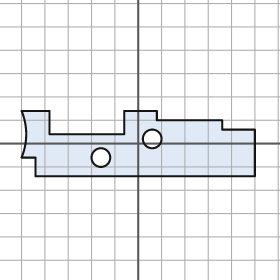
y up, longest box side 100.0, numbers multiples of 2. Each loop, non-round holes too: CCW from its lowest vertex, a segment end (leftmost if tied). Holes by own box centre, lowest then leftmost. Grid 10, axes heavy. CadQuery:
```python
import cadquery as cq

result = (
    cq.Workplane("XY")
    .moveTo(-44.0, -14.0)
    .lineTo(50.0, -14.0)
    .lineTo(50.0, 6.0)
    .lineTo(36.0, 6.0)
    .lineTo(36.0, 10.0)
    .lineTo(8.0, 10.0)
    .lineTo(8.0, 14.0)
    .lineTo(-6.0, 14.0)
    .lineTo(-6.0, 4.0)
    .lineTo(-38.0, 4.0)
    .lineTo(-38.0, 14.0)
    .lineTo(-50.0, 14.0)
    .threePointArc((-48.0, 4.0), (-50.0, -6.0))
    .lineTo(-44.0, -6.0)
    .close()
    .moveTo(-16.0, -6.0)
    .circle(4.0)
    .moveTo(6.0, 2.0)
    .circle(4.0)
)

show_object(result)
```